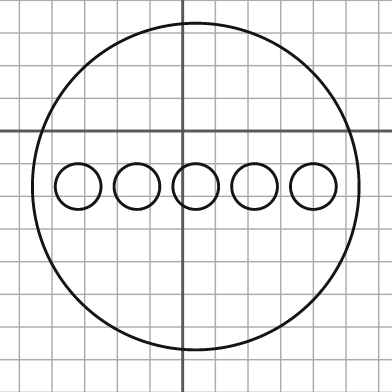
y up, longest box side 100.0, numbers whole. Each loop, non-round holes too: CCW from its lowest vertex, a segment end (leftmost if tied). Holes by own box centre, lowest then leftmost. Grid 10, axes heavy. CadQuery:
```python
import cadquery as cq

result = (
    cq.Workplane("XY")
    .moveTo(4.0, -17.0)
    .circle(50.0)
    .moveTo(-32.0, -17.0)
    .circle(7.0)
    .moveTo(-14.0, -17.0)
    .circle(7.0)
    .moveTo(4.0, -17.0)
    .circle(7.0)
    .moveTo(22.0, -17.0)
    .circle(7.0)
    .moveTo(40.0, -17.0)
    .circle(7.0)
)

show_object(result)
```